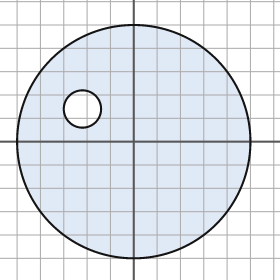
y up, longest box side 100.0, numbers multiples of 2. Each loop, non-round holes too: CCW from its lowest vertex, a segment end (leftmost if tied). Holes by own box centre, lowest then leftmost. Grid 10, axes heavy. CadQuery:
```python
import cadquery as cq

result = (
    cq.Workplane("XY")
    .moveTo(0.0, 0.0)
    .circle(50.0)
    .moveTo(-22.0, 14.0)
    .circle(8.0)
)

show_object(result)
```